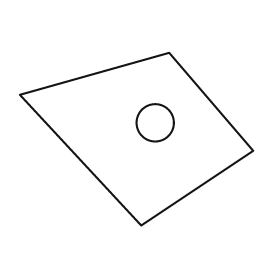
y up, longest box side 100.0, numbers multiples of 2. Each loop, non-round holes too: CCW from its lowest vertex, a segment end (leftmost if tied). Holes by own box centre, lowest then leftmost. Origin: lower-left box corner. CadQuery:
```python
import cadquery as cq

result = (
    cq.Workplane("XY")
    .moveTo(52.0, 0.0)
    .lineTo(100.0, 32.0)
    .lineTo(64.0, 74.0)
    .lineTo(0.0, 56.0)
    .close()
    .moveTo(58.0, 44.0)
    .circle(8.0)
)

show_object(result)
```